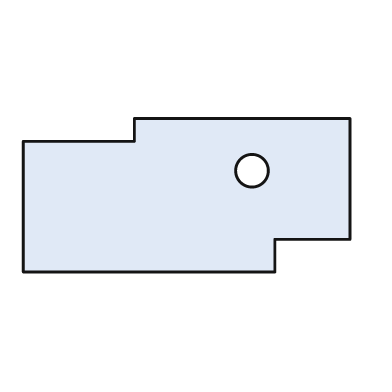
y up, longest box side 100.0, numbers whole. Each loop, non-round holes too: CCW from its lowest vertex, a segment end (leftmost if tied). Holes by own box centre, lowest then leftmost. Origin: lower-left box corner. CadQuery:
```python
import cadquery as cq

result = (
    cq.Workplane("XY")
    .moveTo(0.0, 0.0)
    .lineTo(77.0, 0.0)
    .lineTo(77.0, 10.0)
    .lineTo(100.0, 10.0)
    .lineTo(100.0, 47.0)
    .lineTo(34.0, 47.0)
    .lineTo(34.0, 40.0)
    .lineTo(0.0, 40.0)
    .close()
    .moveTo(70.0, 31.0)
    .circle(5.0)
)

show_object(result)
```